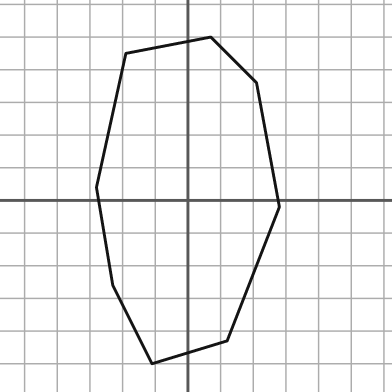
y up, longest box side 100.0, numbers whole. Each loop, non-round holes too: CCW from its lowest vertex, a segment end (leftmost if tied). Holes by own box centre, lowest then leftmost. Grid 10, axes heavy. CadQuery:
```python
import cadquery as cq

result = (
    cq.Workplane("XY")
    .moveTo(-11.0, -50.0)
    .lineTo(12.0, -43.0)
    .lineTo(28.0, -2.0)
    .lineTo(21.0, 36.0)
    .lineTo(7.0, 50.0)
    .lineTo(-19.0, 45.0)
    .lineTo(-28.0, 4.0)
    .lineTo(-23.0, -26.0)
    .close()
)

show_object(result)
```